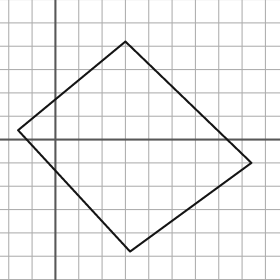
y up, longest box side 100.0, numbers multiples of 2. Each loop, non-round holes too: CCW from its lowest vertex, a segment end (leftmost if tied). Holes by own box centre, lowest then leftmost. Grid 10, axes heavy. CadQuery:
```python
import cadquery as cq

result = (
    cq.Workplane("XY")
    .moveTo(32.0, -48.0)
    .lineTo(84.0, -10.0)
    .lineTo(30.0, 42.0)
    .lineTo(-16.0, 4.0)
    .close()
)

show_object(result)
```